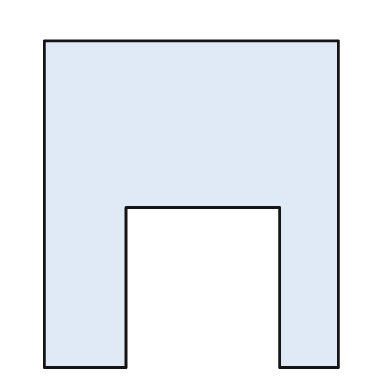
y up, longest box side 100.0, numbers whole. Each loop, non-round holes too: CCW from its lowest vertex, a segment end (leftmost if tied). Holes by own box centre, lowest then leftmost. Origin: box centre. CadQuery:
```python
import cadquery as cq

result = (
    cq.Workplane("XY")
    .moveTo(-45.0, -50.0)
    .lineTo(-20.0, -50.0)
    .lineTo(-20.0, -1.0)
    .lineTo(27.0, -1.0)
    .lineTo(27.0, -50.0)
    .lineTo(45.0, -50.0)
    .lineTo(45.0, 50.0)
    .lineTo(-45.0, 50.0)
    .close()
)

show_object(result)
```